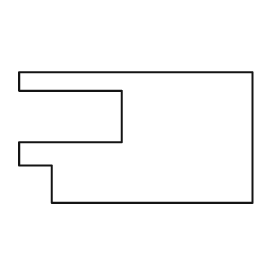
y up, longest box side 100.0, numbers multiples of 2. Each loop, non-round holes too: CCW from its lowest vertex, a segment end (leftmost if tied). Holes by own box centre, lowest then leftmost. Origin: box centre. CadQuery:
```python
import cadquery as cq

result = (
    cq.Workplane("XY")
    .moveTo(-36.0, -28.0)
    .lineTo(50.0, -28.0)
    .lineTo(50.0, 28.0)
    .lineTo(-50.0, 28.0)
    .lineTo(-50.0, 20.0)
    .lineTo(-6.0, 20.0)
    .lineTo(-6.0, -2.0)
    .lineTo(-50.0, -2.0)
    .lineTo(-50.0, -12.0)
    .lineTo(-36.0, -12.0)
    .close()
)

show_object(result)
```